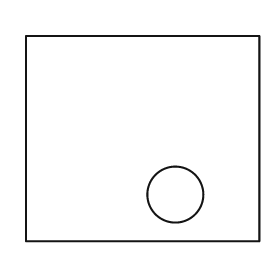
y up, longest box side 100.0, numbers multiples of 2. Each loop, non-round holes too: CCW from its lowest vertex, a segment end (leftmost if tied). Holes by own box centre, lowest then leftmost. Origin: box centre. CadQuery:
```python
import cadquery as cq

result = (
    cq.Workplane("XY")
    .moveTo(-50.0, -44.0)
    .lineTo(50.0, -44.0)
    .lineTo(50.0, 44.0)
    .lineTo(-50.0, 44.0)
    .close()
    .moveTo(14.0, -24.0)
    .circle(12.0)
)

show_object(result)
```